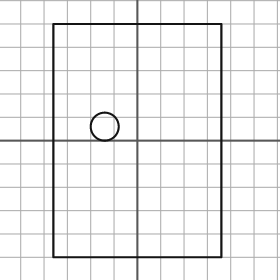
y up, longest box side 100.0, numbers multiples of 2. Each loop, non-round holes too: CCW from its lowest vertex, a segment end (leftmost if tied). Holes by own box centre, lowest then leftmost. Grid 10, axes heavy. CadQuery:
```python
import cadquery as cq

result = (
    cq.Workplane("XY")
    .moveTo(-36.0, -50.0)
    .lineTo(36.0, -50.0)
    .lineTo(36.0, 50.0)
    .lineTo(-36.0, 50.0)
    .close()
    .moveTo(-14.0, 6.0)
    .circle(6.0)
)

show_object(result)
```